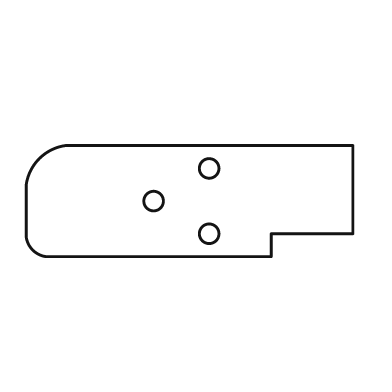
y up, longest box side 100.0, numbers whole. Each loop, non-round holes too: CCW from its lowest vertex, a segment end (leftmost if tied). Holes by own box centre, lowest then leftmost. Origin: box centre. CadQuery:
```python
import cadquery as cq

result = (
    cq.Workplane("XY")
    .moveTo(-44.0, -17.0)
    .lineTo(25.0, -17.0)
    .lineTo(25.0, -10.0)
    .lineTo(50.0, -10.0)
    .lineTo(50.0, 17.0)
    .lineTo(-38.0, 17.0)
    .threePointArc((-46.0, 13.0), (-50.0, 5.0))
    .lineTo(-50.0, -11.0)
    .threePointArc((-48.0, -15.0), (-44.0, -17.0))
    .close()
    .moveTo(6.0, -10.0)
    .circle(3.0)
    .moveTo(-11.0, 0.0)
    .circle(3.0)
    .moveTo(6.0, 10.0)
    .circle(3.0)
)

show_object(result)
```